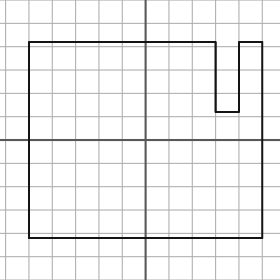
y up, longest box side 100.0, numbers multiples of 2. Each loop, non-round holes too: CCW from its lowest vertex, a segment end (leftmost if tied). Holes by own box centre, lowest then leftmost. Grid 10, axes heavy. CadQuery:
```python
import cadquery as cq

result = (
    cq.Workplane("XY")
    .moveTo(-50.0, -42.0)
    .lineTo(50.0, -42.0)
    .lineTo(50.0, 42.0)
    .lineTo(40.0, 42.0)
    .lineTo(40.0, 12.0)
    .lineTo(30.0, 12.0)
    .lineTo(30.0, 42.0)
    .lineTo(-50.0, 42.0)
    .close()
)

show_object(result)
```